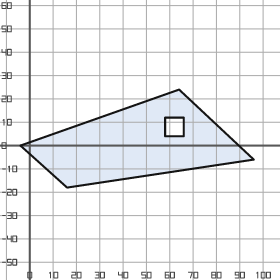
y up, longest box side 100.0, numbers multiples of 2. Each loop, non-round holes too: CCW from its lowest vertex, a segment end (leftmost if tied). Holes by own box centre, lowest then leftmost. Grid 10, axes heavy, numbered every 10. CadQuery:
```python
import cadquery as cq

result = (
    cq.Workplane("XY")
    .moveTo(16.0, -18.0)
    .lineTo(96.0, -6.0)
    .lineTo(64.0, 24.0)
    .lineTo(-4.0, 0.0)
    .close()
    .moveTo(58.0, 4.0)
    .lineTo(66.0, 4.0)
    .lineTo(66.0, 12.0)
    .lineTo(58.0, 12.0)
    .close()
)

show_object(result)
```